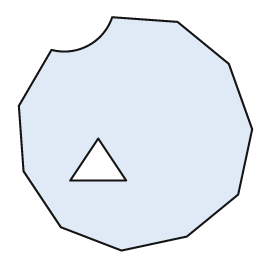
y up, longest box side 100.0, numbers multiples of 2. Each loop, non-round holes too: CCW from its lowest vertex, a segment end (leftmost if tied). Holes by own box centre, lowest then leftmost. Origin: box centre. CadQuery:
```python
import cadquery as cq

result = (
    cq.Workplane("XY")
    .moveTo(-6.0, -50.0)
    .lineTo(22.0, -44.0)
    .lineTo(44.0, -26.0)
    .lineTo(50.0, 2.0)
    .lineTo(40.0, 30.0)
    .lineTo(18.0, 48.0)
    .lineTo(-10.0, 50.0)
    .threePointArc((-20.0, 38.0), (-36.0, 36.0))
    .lineTo(-50.0, 12.0)
    .lineTo(-48.0, -16.0)
    .lineTo(-32.0, -40.0)
    .close()
    .moveTo(-28.0, -20.0)
    .lineTo(-4.0, -20.0)
    .lineTo(-16.0, -2.0)
    .close()
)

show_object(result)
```